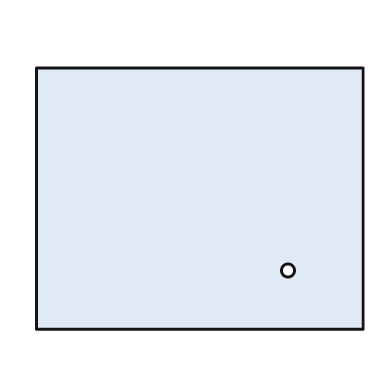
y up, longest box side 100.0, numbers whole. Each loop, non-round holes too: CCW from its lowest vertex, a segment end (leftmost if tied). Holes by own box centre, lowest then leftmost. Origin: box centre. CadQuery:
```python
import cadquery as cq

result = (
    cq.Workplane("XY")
    .moveTo(-50.0, -40.0)
    .lineTo(50.0, -40.0)
    .lineTo(50.0, 40.0)
    .lineTo(-50.0, 40.0)
    .close()
    .moveTo(27.0, -22.0)
    .circle(2.0)
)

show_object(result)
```